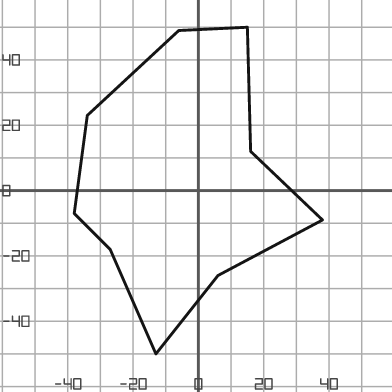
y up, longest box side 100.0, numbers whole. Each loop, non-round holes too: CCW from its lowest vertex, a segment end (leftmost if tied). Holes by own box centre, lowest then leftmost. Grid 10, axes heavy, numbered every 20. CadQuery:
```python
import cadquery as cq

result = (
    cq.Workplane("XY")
    .moveTo(-13.0, -50.0)
    .lineTo(6.0, -26.0)
    .lineTo(38.0, -9.0)
    .lineTo(16.0, 12.0)
    .lineTo(15.0, 50.0)
    .lineTo(-6.0, 49.0)
    .lineTo(-34.0, 23.0)
    .lineTo(-38.0, -7.0)
    .lineTo(-27.0, -18.0)
    .close()
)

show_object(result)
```